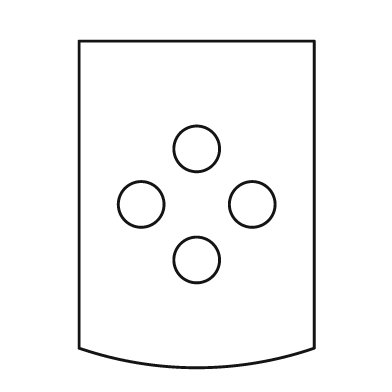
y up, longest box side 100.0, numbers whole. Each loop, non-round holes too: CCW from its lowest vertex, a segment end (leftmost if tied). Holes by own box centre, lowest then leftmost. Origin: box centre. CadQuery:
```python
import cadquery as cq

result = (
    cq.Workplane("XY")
    .moveTo(-36.0, -44.0)
    .threePointArc((0.0, -50.0), (36.0, -44.0))
    .lineTo(36.0, 50.0)
    .lineTo(-36.0, 50.0)
    .close()
    .moveTo(0.0, -17.0)
    .circle(7.0)
    .moveTo(-17.0, 0.0)
    .circle(7.0)
    .moveTo(17.0, 0.0)
    .circle(7.0)
    .moveTo(0.0, 17.0)
    .circle(7.0)
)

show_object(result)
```